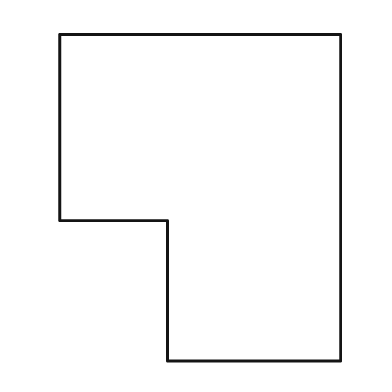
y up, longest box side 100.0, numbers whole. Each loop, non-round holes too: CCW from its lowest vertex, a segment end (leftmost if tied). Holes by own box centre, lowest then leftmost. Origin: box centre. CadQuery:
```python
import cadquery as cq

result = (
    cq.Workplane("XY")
    .moveTo(-10.0, -50.0)
    .lineTo(43.0, -50.0)
    .lineTo(43.0, 50.0)
    .lineTo(-43.0, 50.0)
    .lineTo(-43.0, -7.0)
    .lineTo(-10.0, -7.0)
    .close()
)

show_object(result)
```